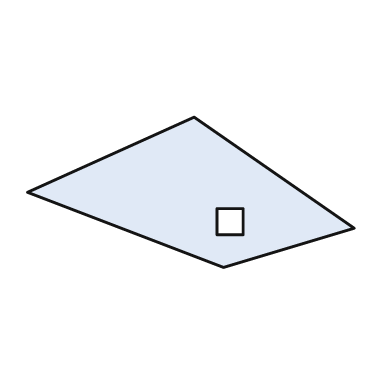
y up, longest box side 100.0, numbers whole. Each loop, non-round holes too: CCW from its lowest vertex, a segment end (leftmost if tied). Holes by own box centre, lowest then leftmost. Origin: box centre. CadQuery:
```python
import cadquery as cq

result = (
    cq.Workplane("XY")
    .moveTo(10.0, -23.0)
    .lineTo(50.0, -11.0)
    .lineTo(1.0, 23.0)
    .lineTo(-50.0, 0.0)
    .close()
    .moveTo(8.0, -13.0)
    .lineTo(16.0, -13.0)
    .lineTo(16.0, -5.0)
    .lineTo(8.0, -5.0)
    .close()
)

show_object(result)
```